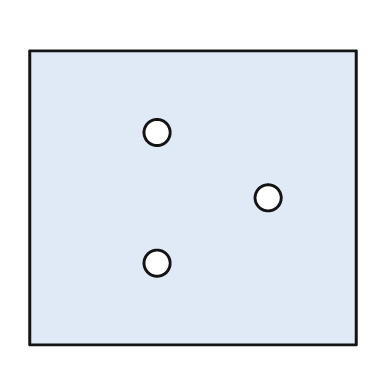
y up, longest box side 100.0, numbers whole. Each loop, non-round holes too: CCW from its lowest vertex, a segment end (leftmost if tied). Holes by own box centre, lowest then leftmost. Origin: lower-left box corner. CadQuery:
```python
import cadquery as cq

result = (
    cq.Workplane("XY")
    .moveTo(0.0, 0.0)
    .lineTo(100.0, 0.0)
    .lineTo(100.0, 90.0)
    .lineTo(0.0, 90.0)
    .close()
    .moveTo(39.0, 25.0)
    .circle(4.0)
    .moveTo(73.0, 45.0)
    .circle(4.0)
    .moveTo(39.0, 65.0)
    .circle(4.0)
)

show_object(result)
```